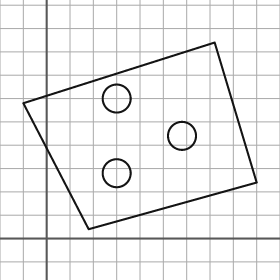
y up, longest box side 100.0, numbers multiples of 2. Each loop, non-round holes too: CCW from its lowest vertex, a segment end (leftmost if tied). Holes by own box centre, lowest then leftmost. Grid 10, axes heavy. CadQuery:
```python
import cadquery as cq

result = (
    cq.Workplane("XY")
    .moveTo(18.0, 4.0)
    .lineTo(90.0, 24.0)
    .lineTo(72.0, 84.0)
    .lineTo(-10.0, 58.0)
    .close()
    .moveTo(30.0, 28.0)
    .circle(6.0)
    .moveTo(58.0, 44.0)
    .circle(6.0)
    .moveTo(30.0, 60.0)
    .circle(6.0)
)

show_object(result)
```